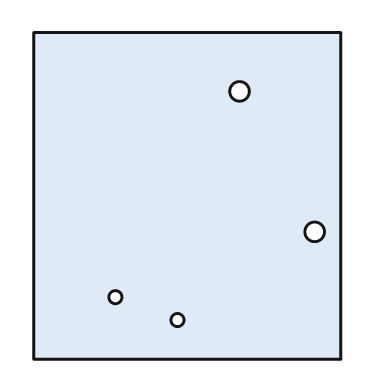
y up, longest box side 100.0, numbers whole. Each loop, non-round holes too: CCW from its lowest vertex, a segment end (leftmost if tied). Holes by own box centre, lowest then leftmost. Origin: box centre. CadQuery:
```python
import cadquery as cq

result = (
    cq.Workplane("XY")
    .moveTo(-47.0, -50.0)
    .lineTo(47.0, -50.0)
    .lineTo(47.0, 50.0)
    .lineTo(-47.0, 50.0)
    .close()
    .moveTo(-3.0, -38.0)
    .circle(2.0)
    .moveTo(-22.0, -31.0)
    .circle(2.0)
    .moveTo(39.0, -11.0)
    .circle(3.0)
    .moveTo(16.0, 32.0)
    .circle(3.0)
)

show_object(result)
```